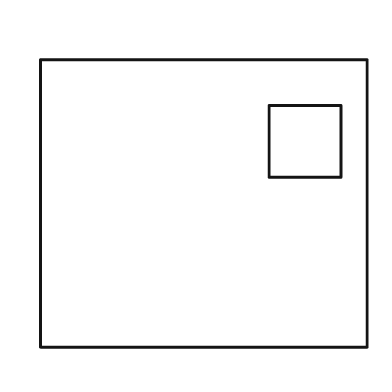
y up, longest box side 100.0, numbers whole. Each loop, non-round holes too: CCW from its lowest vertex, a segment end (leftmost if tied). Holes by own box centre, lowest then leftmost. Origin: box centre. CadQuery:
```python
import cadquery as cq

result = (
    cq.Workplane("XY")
    .moveTo(-50.0, -44.0)
    .lineTo(50.0, -44.0)
    .lineTo(50.0, 44.0)
    .lineTo(-50.0, 44.0)
    .close()
    .moveTo(20.0, 8.0)
    .lineTo(42.0, 8.0)
    .lineTo(42.0, 30.0)
    .lineTo(20.0, 30.0)
    .close()
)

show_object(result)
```